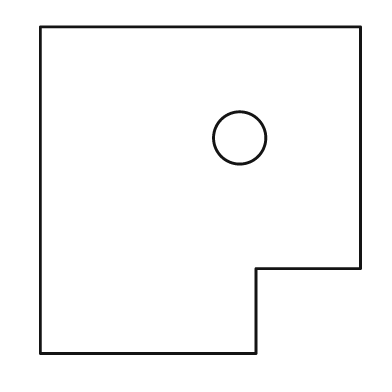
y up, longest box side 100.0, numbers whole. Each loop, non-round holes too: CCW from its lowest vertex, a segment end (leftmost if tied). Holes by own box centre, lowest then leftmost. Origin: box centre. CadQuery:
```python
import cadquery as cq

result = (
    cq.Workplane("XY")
    .moveTo(-49.0, -50.0)
    .lineTo(17.0, -50.0)
    .lineTo(17.0, -24.0)
    .lineTo(49.0, -24.0)
    .lineTo(49.0, 50.0)
    .lineTo(-49.0, 50.0)
    .close()
    .moveTo(12.0, 16.0)
    .circle(8.0)
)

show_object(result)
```